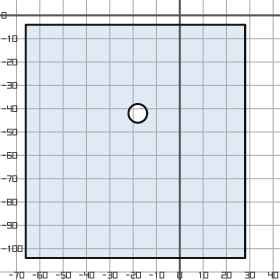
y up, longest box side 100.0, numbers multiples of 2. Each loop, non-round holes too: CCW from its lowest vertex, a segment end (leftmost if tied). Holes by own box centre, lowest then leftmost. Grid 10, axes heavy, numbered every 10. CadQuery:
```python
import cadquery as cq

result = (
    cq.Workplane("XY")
    .moveTo(-66.0, -104.0)
    .lineTo(28.0, -104.0)
    .lineTo(28.0, -4.0)
    .lineTo(-66.0, -4.0)
    .close()
    .moveTo(-18.0, -42.0)
    .circle(4.0)
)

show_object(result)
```